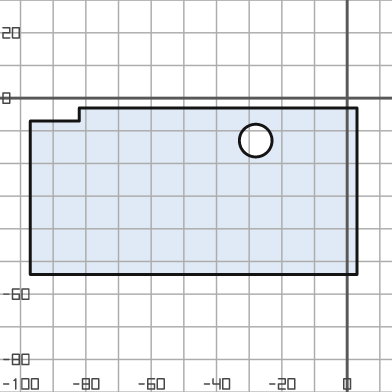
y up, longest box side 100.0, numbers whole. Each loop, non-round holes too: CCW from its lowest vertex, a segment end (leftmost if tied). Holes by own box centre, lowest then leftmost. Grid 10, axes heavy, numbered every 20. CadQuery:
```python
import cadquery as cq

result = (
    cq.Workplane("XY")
    .moveTo(-97.0, -54.0)
    .lineTo(3.0, -54.0)
    .lineTo(3.0, -3.0)
    .lineTo(-82.0, -3.0)
    .lineTo(-82.0, -7.0)
    .lineTo(-97.0, -7.0)
    .close()
    .moveTo(-28.0, -13.0)
    .circle(5.0)
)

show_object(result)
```